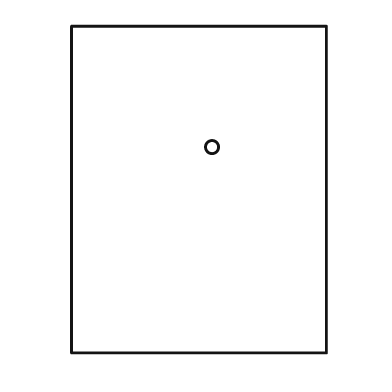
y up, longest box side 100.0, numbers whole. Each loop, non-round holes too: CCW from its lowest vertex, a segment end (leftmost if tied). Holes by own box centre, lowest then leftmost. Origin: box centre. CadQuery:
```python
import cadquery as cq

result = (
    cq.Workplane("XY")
    .moveTo(-39.0, -50.0)
    .lineTo(39.0, -50.0)
    .lineTo(39.0, 50.0)
    .lineTo(-39.0, 50.0)
    .close()
    .moveTo(4.0, 13.0)
    .circle(2.0)
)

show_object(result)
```